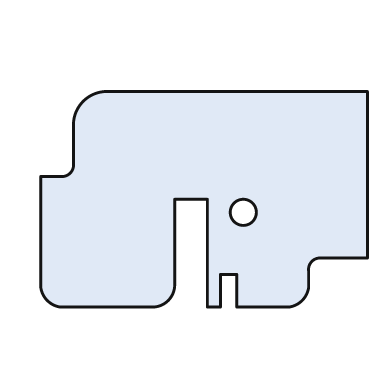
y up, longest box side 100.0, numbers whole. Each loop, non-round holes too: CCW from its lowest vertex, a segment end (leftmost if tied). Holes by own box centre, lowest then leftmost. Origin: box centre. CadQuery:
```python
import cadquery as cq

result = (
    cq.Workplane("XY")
    .moveTo(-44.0, -33.0)
    .lineTo(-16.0, -33.0)
    .threePointArc((-11.0, -31.0), (-9.0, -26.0))
    .lineTo(-9.0, 0.0)
    .lineTo(1.0, 0.0)
    .lineTo(1.0, -33.0)
    .lineTo(5.0, -33.0)
    .lineTo(5.0, -23.0)
    .lineTo(10.0, -23.0)
    .lineTo(10.0, -33.0)
    .lineTo(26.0, -33.0)
    .threePointArc((30.0, -31.0), (32.0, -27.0))
    .lineTo(32.0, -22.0)
    .threePointArc((33.0, -19.0), (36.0, -18.0))
    .lineTo(50.0, -18.0)
    .lineTo(50.0, 33.0)
    .lineTo(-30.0, 33.0)
    .threePointArc((-37.0, 30.0), (-40.0, 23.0))
    .lineTo(-40.0, 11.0)
    .threePointArc((-41.0, 8.0), (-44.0, 7.0))
    .lineTo(-50.0, 7.0)
    .lineTo(-50.0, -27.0)
    .threePointArc((-48.0, -31.0), (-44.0, -33.0))
    .close()
    .moveTo(12.0, -4.0)
    .circle(4.0)
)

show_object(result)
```